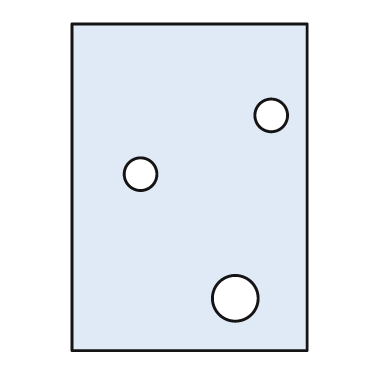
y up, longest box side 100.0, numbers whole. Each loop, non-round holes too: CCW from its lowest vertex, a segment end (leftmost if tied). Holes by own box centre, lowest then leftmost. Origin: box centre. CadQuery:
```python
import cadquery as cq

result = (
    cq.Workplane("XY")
    .moveTo(-36.0, -50.0)
    .lineTo(36.0, -50.0)
    .lineTo(36.0, 50.0)
    .lineTo(-36.0, 50.0)
    .close()
    .moveTo(14.0, -34.0)
    .circle(7.0)
    .moveTo(-15.0, 4.0)
    .circle(5.0)
    .moveTo(25.0, 22.0)
    .circle(5.0)
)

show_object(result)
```